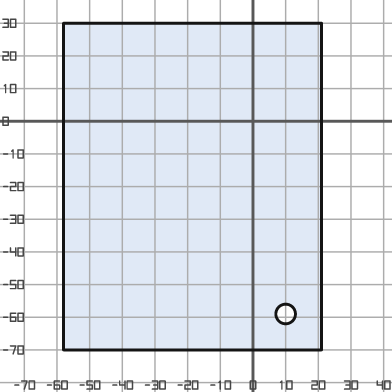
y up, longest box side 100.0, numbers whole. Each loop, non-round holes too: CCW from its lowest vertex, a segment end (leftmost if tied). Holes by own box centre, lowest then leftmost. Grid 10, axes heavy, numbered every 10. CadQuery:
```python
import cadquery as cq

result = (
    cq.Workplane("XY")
    .moveTo(-58.0, -70.0)
    .lineTo(21.0, -70.0)
    .lineTo(21.0, 30.0)
    .lineTo(-58.0, 30.0)
    .close()
    .moveTo(10.0, -59.0)
    .circle(3.0)
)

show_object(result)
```